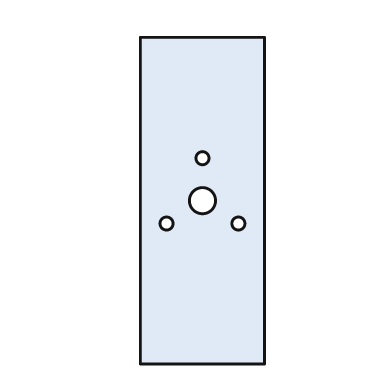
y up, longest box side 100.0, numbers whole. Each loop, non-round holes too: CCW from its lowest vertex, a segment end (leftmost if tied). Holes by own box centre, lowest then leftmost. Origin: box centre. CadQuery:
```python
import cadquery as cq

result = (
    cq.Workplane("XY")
    .moveTo(-19.0, -50.0)
    .lineTo(19.0, -50.0)
    .lineTo(19.0, 50.0)
    .lineTo(-19.0, 50.0)
    .close()
    .moveTo(-11.0, -7.0)
    .circle(2.0)
    .moveTo(11.0, -7.0)
    .circle(2.0)
    .moveTo(0.0, 0.0)
    .circle(4.0)
    .moveTo(0.0, 13.0)
    .circle(2.0)
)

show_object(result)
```